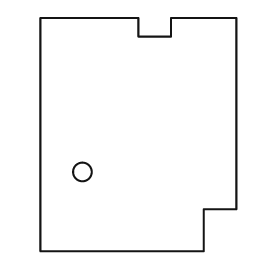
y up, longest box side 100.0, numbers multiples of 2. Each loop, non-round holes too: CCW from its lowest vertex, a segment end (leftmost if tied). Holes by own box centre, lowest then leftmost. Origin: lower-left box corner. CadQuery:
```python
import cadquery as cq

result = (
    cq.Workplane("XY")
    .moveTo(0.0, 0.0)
    .lineTo(70.0, 0.0)
    .lineTo(70.0, 18.0)
    .lineTo(84.0, 18.0)
    .lineTo(84.0, 100.0)
    .lineTo(56.0, 100.0)
    .lineTo(56.0, 92.0)
    .lineTo(42.0, 92.0)
    .lineTo(42.0, 100.0)
    .lineTo(0.0, 100.0)
    .close()
    .moveTo(18.0, 34.0)
    .circle(4.0)
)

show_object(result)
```